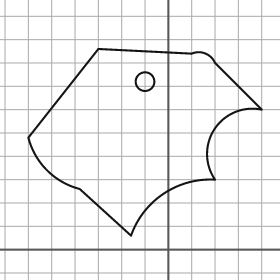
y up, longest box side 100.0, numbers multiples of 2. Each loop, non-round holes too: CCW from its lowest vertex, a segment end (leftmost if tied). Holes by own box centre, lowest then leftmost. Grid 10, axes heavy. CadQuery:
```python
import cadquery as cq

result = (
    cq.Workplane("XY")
    .moveTo(-16.0, 6.0)
    .threePointArc((-2.0, 24.0), (20.0, 30.0))
    .threePointArc((20.0, 52.0), (40.0, 60.0))
    .lineTo(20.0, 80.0)
    .threePointArc((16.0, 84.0), (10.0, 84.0))
    .lineTo(-30.0, 86.0)
    .lineTo(-60.0, 48.0)
    .threePointArc((-52.0, 34.0), (-38.0, 26.0))
    .close()
    .moveTo(-10.0, 72.0)
    .circle(4.0)
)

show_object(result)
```